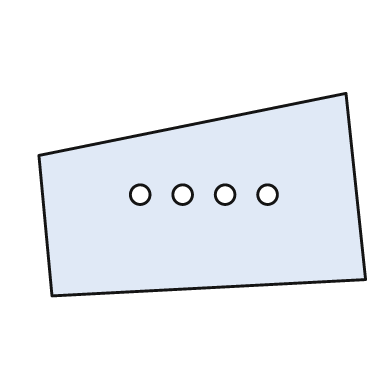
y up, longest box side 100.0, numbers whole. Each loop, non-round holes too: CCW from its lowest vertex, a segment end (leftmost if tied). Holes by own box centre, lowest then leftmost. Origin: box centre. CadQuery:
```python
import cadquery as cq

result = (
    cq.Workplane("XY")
    .moveTo(-46.0, -31.0)
    .lineTo(50.0, -26.0)
    .lineTo(44.0, 31.0)
    .lineTo(-50.0, 12.0)
    .close()
    .moveTo(-19.0, 0.0)
    .circle(3.0)
    .moveTo(-6.0, 0.0)
    .circle(3.0)
    .moveTo(7.0, 0.0)
    .circle(3.0)
    .moveTo(20.0, 0.0)
    .circle(3.0)
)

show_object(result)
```